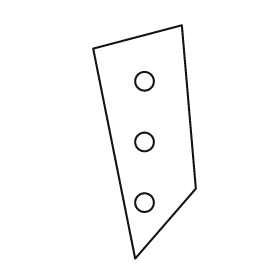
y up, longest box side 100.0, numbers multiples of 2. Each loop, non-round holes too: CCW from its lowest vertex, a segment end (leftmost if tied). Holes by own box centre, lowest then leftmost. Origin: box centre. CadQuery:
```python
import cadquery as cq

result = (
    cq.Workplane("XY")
    .moveTo(-4.0, -50.0)
    .lineTo(22.0, -20.0)
    .lineTo(16.0, 50.0)
    .lineTo(-22.0, 40.0)
    .close()
    .moveTo(0.0, -26.0)
    .circle(4.0)
    .moveTo(0.0, 0.0)
    .circle(4.0)
    .moveTo(0.0, 26.0)
    .circle(4.0)
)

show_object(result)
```